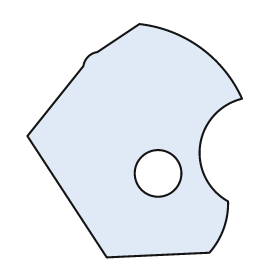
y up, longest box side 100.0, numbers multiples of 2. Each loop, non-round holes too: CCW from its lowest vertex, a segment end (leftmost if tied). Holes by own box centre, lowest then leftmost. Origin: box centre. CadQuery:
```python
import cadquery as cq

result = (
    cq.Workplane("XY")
    .moveTo(-12.0, -50.0)
    .lineTo(32.0, -48.0)
    .threePointArc((38.0, -38.0), (40.0, -26.0))
    .threePointArc((28.0, -2.0), (46.0, 18.0))
    .threePointArc((28.0, 40.0), (2.0, 50.0))
    .lineTo(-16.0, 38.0)
    .threePointArc((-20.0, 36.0), (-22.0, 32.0))
    .lineTo(-46.0, 2.0)
    .close()
    .moveTo(10.0, -14.0)
    .circle(10.0)
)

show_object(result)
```